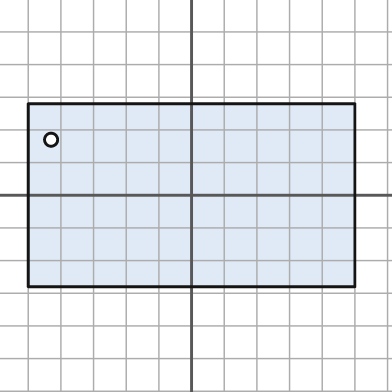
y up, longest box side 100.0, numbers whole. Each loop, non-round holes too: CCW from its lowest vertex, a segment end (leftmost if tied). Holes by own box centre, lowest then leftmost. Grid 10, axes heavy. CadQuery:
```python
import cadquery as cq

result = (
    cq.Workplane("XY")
    .moveTo(-50.0, -28.0)
    .lineTo(50.0, -28.0)
    .lineTo(50.0, 28.0)
    .lineTo(-50.0, 28.0)
    .close()
    .moveTo(-43.0, 17.0)
    .circle(2.0)
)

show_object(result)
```